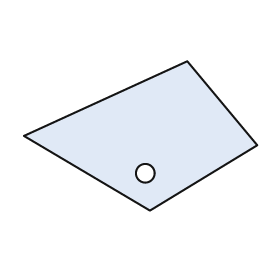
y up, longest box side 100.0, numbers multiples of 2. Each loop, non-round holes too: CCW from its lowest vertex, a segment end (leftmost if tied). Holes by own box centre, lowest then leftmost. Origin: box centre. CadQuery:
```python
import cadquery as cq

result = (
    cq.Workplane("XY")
    .moveTo(4.0, -32.0)
    .lineTo(50.0, -4.0)
    .lineTo(20.0, 32.0)
    .lineTo(-50.0, 0.0)
    .close()
    .moveTo(2.0, -16.0)
    .circle(4.0)
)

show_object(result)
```